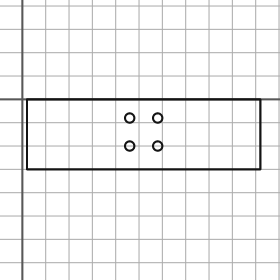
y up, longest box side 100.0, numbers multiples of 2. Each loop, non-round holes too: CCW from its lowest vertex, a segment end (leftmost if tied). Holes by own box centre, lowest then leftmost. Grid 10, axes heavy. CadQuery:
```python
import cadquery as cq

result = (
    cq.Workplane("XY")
    .moveTo(2.0, -30.0)
    .lineTo(102.0, -30.0)
    .lineTo(102.0, 0.0)
    .lineTo(2.0, 0.0)
    .close()
    .moveTo(46.0, -20.0)
    .circle(2.0)
    .moveTo(58.0, -20.0)
    .circle(2.0)
    .moveTo(46.0, -8.0)
    .circle(2.0)
    .moveTo(58.0, -8.0)
    .circle(2.0)
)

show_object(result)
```